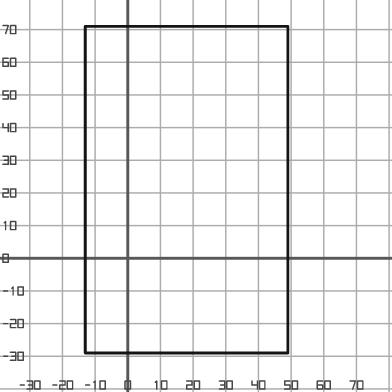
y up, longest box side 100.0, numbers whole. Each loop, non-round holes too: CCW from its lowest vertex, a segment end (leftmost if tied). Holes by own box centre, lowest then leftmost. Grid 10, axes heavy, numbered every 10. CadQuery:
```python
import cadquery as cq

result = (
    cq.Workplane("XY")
    .moveTo(-13.0, -29.0)
    .lineTo(49.0, -29.0)
    .lineTo(49.0, 71.0)
    .lineTo(-13.0, 71.0)
    .close()
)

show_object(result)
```